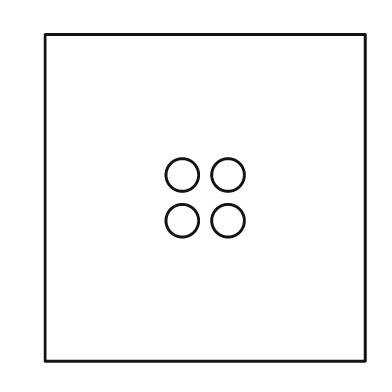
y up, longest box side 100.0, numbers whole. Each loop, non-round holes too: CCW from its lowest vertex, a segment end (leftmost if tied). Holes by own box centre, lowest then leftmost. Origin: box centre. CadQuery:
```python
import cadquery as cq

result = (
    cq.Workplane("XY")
    .moveTo(-49.0, -50.0)
    .lineTo(49.0, -50.0)
    .lineTo(49.0, 50.0)
    .lineTo(-49.0, 50.0)
    .close()
    .moveTo(-7.0, -7.0)
    .circle(5.0)
    .moveTo(7.0, -7.0)
    .circle(5.0)
    .moveTo(-7.0, 7.0)
    .circle(5.0)
    .moveTo(7.0, 7.0)
    .circle(5.0)
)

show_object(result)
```